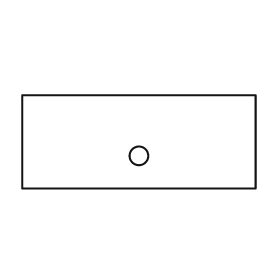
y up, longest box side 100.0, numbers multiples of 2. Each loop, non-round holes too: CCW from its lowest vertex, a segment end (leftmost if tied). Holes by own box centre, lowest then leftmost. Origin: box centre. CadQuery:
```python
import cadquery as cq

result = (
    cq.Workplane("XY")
    .moveTo(-50.0, -20.0)
    .lineTo(50.0, -20.0)
    .lineTo(50.0, 20.0)
    .lineTo(-50.0, 20.0)
    .close()
    .moveTo(0.0, -6.0)
    .circle(4.0)
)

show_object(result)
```